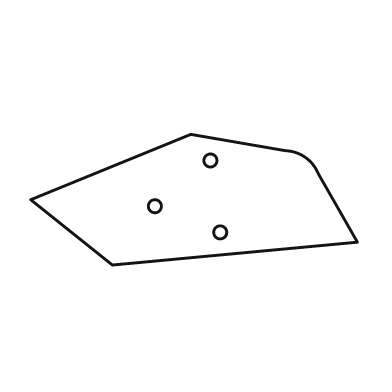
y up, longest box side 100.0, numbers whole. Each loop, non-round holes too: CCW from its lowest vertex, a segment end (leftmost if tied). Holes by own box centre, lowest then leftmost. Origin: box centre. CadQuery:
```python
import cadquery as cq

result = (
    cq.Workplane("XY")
    .moveTo(-25.0, -20.0)
    .lineTo(50.0, -13.0)
    .lineTo(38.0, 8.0)
    .threePointArc((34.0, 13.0), (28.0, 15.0))
    .lineTo(-1.0, 20.0)
    .lineTo(-50.0, 0.0)
    .close()
    .moveTo(8.0, -10.0)
    .circle(2.0)
    .moveTo(-12.0, -2.0)
    .circle(2.0)
    .moveTo(5.0, 12.0)
    .circle(2.0)
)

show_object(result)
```